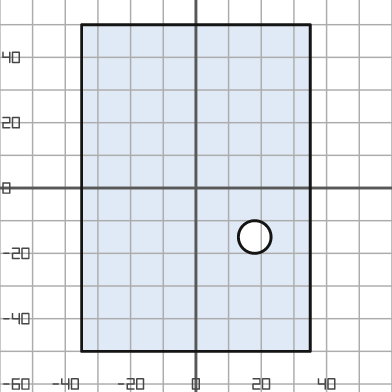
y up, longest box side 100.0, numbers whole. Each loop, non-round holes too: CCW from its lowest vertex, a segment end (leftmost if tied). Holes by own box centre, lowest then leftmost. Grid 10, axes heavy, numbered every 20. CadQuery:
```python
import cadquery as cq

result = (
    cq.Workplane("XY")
    .moveTo(-35.0, -50.0)
    .lineTo(35.0, -50.0)
    .lineTo(35.0, 50.0)
    .lineTo(-35.0, 50.0)
    .close()
    .moveTo(18.0, -15.0)
    .circle(5.0)
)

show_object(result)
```